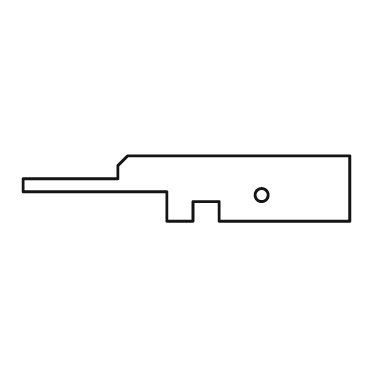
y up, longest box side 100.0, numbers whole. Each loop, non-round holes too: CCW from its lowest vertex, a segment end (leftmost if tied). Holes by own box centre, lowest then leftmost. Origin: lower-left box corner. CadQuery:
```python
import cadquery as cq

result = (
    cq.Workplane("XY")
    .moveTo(44.0, 0.0)
    .lineTo(52.0, 0.0)
    .lineTo(52.0, 6.0)
    .lineTo(60.0, 6.0)
    .lineTo(60.0, 0.0)
    .lineTo(100.0, 0.0)
    .lineTo(100.0, 20.0)
    .lineTo(32.0, 20.0)
    .lineTo(29.0, 17.0)
    .lineTo(29.0, 13.0)
    .lineTo(0.0, 13.0)
    .lineTo(0.0, 9.0)
    .lineTo(44.0, 9.0)
    .close()
    .moveTo(73.0, 8.0)
    .circle(2.0)
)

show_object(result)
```